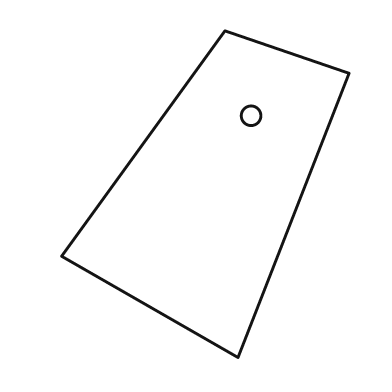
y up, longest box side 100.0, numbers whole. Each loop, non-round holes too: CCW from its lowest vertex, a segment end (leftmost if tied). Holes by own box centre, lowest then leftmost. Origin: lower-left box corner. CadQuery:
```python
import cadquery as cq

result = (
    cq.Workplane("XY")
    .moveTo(54.0, 0.0)
    .lineTo(88.0, 87.0)
    .lineTo(50.0, 100.0)
    .lineTo(0.0, 31.0)
    .close()
    .moveTo(58.0, 74.0)
    .circle(3.0)
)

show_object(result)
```